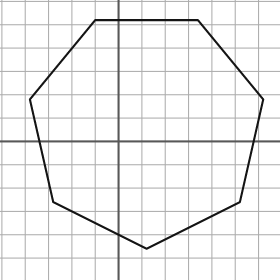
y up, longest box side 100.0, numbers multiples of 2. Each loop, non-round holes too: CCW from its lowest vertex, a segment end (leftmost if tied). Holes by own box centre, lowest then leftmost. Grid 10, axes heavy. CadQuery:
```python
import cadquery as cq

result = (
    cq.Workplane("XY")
    .moveTo(12.0, -46.0)
    .lineTo(52.0, -26.0)
    .lineTo(62.0, 18.0)
    .lineTo(34.0, 52.0)
    .lineTo(-10.0, 52.0)
    .lineTo(-38.0, 18.0)
    .lineTo(-28.0, -26.0)
    .close()
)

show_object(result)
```